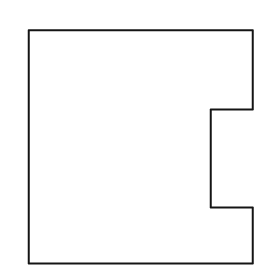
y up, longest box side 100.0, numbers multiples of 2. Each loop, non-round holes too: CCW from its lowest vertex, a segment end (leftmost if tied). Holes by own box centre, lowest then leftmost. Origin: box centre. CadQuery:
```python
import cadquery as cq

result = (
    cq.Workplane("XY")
    .moveTo(-48.0, -50.0)
    .lineTo(48.0, -50.0)
    .lineTo(48.0, -26.0)
    .lineTo(30.0, -26.0)
    .lineTo(30.0, 16.0)
    .lineTo(48.0, 16.0)
    .lineTo(48.0, 50.0)
    .lineTo(-48.0, 50.0)
    .close()
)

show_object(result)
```